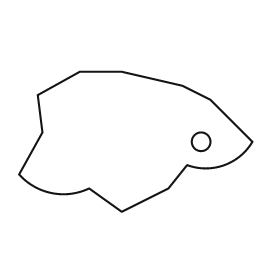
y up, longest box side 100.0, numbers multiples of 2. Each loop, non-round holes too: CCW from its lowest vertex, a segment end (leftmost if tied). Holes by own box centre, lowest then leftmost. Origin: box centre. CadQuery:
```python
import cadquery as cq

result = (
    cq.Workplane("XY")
    .moveTo(-6.0, -30.0)
    .lineTo(14.0, -20.0)
    .lineTo(22.0, -10.0)
    .threePointArc((38.0, -10.0), (50.0, 0.0))
    .lineTo(32.0, 18.0)
    .lineTo(20.0, 24.0)
    .lineTo(-6.0, 30.0)
    .lineTo(-24.0, 30.0)
    .lineTo(-42.0, 20.0)
    .lineTo(-40.0, 4.0)
    .lineTo(-50.0, -14.0)
    .threePointArc((-36.0, -22.0), (-20.0, -20.0))
    .close()
    .moveTo(28.0, 0.0)
    .circle(4.0)
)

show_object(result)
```